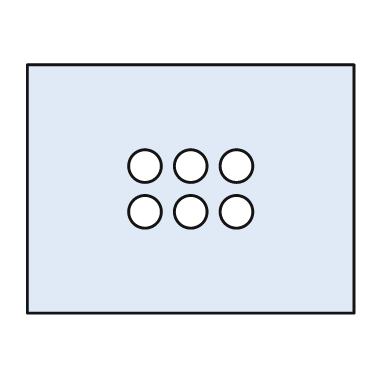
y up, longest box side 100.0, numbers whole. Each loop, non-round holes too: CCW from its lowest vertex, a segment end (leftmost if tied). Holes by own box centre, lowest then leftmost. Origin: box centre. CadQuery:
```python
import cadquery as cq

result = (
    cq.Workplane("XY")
    .moveTo(-50.0, -38.0)
    .lineTo(50.0, -38.0)
    .lineTo(50.0, 38.0)
    .lineTo(-50.0, 38.0)
    .close()
    .moveTo(-14.0, -7.0)
    .circle(5.0)
    .moveTo(0.0, -7.0)
    .circle(5.0)
    .moveTo(14.0, -7.0)
    .circle(5.0)
    .moveTo(-14.0, 7.0)
    .circle(5.0)
    .moveTo(0.0, 7.0)
    .circle(5.0)
    .moveTo(14.0, 7.0)
    .circle(5.0)
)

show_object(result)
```